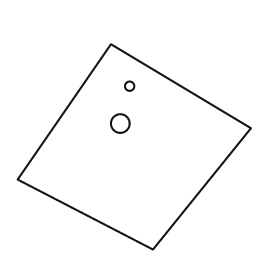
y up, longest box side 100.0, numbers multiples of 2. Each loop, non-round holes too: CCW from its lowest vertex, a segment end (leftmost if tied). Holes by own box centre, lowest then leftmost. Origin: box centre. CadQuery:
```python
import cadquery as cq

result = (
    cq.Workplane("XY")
    .moveTo(8.0, -44.0)
    .lineTo(50.0, 8.0)
    .lineTo(-10.0, 44.0)
    .lineTo(-50.0, -14.0)
    .close()
    .moveTo(-6.0, 10.0)
    .circle(4.0)
    .moveTo(-2.0, 26.0)
    .circle(2.0)
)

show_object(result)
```